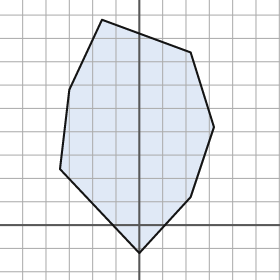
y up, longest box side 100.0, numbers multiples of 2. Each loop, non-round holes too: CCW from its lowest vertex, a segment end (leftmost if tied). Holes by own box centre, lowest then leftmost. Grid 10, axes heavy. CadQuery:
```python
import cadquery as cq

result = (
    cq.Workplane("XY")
    .moveTo(0.0, -12.0)
    .lineTo(22.0, 12.0)
    .lineTo(32.0, 42.0)
    .lineTo(22.0, 74.0)
    .lineTo(-16.0, 88.0)
    .lineTo(-30.0, 58.0)
    .lineTo(-34.0, 24.0)
    .close()
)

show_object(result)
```